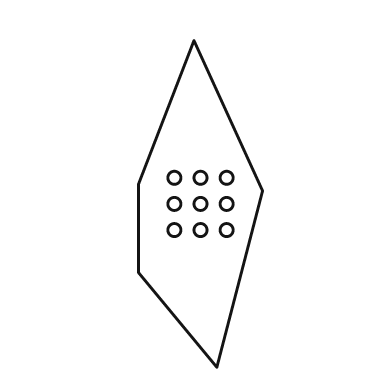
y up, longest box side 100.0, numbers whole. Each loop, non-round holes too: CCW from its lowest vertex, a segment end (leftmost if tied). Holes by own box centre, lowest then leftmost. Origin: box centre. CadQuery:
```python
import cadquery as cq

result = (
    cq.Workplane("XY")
    .moveTo(5.0, -50.0)
    .lineTo(19.0, 4.0)
    .lineTo(-2.0, 50.0)
    .lineTo(-19.0, 6.0)
    .lineTo(-19.0, -21.0)
    .close()
    .moveTo(-8.0, -8.0)
    .circle(2.0)
    .moveTo(0.0, -8.0)
    .circle(2.0)
    .moveTo(8.0, -8.0)
    .circle(2.0)
    .moveTo(-8.0, 0.0)
    .circle(2.0)
    .moveTo(0.0, 0.0)
    .circle(2.0)
    .moveTo(8.0, 0.0)
    .circle(2.0)
    .moveTo(-8.0, 8.0)
    .circle(2.0)
    .moveTo(0.0, 8.0)
    .circle(2.0)
    .moveTo(8.0, 8.0)
    .circle(2.0)
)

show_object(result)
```